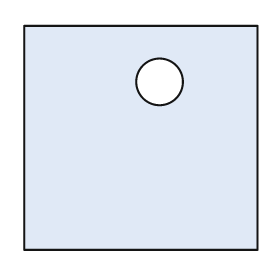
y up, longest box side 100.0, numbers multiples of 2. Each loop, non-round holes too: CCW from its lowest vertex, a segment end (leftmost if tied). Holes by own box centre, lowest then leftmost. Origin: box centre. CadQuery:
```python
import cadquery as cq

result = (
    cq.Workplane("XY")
    .moveTo(-50.0, -48.0)
    .lineTo(50.0, -48.0)
    .lineTo(50.0, 48.0)
    .lineTo(-50.0, 48.0)
    .close()
    .moveTo(8.0, 24.0)
    .circle(10.0)
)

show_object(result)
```